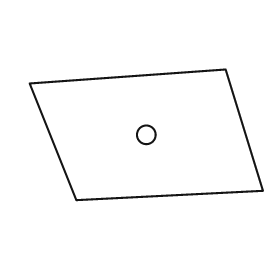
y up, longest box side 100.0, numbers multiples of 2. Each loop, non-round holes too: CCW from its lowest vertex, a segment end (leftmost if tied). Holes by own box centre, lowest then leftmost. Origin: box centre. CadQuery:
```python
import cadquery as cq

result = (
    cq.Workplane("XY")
    .moveTo(-30.0, -28.0)
    .lineTo(50.0, -24.0)
    .lineTo(34.0, 28.0)
    .lineTo(-50.0, 22.0)
    .close()
    .moveTo(0.0, 0.0)
    .circle(4.0)
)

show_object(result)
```